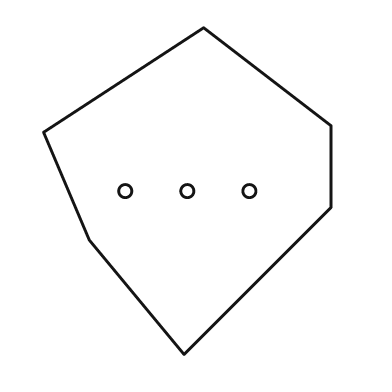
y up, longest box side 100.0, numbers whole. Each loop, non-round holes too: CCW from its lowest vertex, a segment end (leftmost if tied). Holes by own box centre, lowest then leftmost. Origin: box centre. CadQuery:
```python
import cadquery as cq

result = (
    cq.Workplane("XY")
    .moveTo(-1.0, -50.0)
    .lineTo(44.0, -5.0)
    .lineTo(44.0, 20.0)
    .lineTo(5.0, 50.0)
    .lineTo(-44.0, 18.0)
    .lineTo(-30.0, -15.0)
    .close()
    .moveTo(-19.0, 0.0)
    .circle(2.0)
    .moveTo(0.0, 0.0)
    .circle(2.0)
    .moveTo(19.0, 0.0)
    .circle(2.0)
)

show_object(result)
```